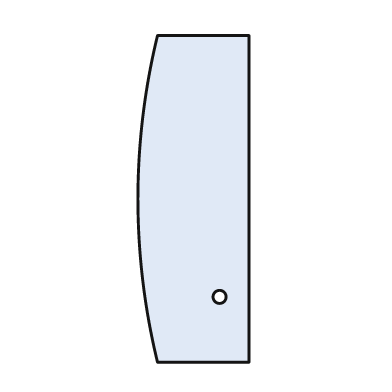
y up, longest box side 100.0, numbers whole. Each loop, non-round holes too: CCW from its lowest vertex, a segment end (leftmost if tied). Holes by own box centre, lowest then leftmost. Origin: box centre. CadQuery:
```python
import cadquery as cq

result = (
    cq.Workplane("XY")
    .moveTo(-11.0, -50.0)
    .lineTo(17.0, -50.0)
    .lineTo(17.0, 50.0)
    .lineTo(-11.0, 50.0)
    .threePointArc((-17.0, 0.0), (-11.0, -50.0))
    .close()
    .moveTo(8.0, -30.0)
    .circle(2.0)
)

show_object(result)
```